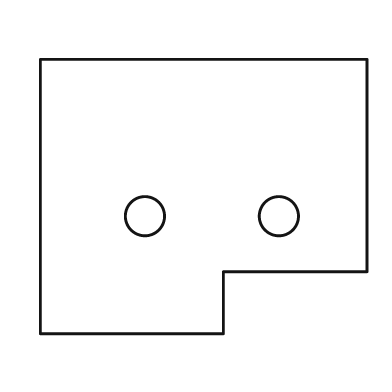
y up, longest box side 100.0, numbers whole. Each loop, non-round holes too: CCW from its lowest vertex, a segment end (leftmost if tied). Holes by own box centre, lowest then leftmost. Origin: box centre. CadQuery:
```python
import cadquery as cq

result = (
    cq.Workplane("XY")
    .moveTo(-50.0, -42.0)
    .lineTo(6.0, -42.0)
    .lineTo(6.0, -23.0)
    .lineTo(50.0, -23.0)
    .lineTo(50.0, 42.0)
    .lineTo(-50.0, 42.0)
    .close()
    .moveTo(-18.0, -6.0)
    .circle(6.0)
    .moveTo(23.0, -6.0)
    .circle(6.0)
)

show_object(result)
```